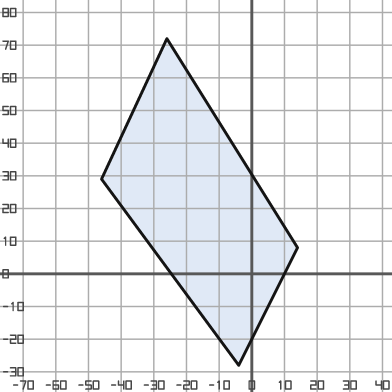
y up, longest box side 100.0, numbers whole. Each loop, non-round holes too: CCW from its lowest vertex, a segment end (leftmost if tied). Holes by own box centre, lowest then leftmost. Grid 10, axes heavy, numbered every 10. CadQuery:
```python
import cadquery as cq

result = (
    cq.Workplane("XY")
    .moveTo(-4.0, -28.0)
    .lineTo(14.0, 8.0)
    .lineTo(-26.0, 72.0)
    .lineTo(-46.0, 29.0)
    .close()
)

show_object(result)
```